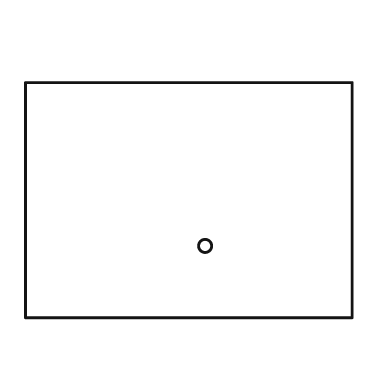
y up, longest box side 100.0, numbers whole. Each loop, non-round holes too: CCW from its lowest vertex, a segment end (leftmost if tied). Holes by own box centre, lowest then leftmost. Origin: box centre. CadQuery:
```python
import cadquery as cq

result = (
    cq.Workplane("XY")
    .moveTo(-50.0, -36.0)
    .lineTo(50.0, -36.0)
    .lineTo(50.0, 36.0)
    .lineTo(-50.0, 36.0)
    .close()
    .moveTo(5.0, -14.0)
    .circle(2.0)
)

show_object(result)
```